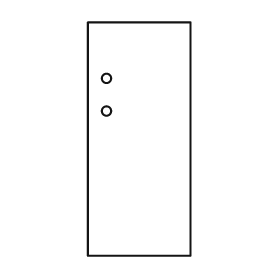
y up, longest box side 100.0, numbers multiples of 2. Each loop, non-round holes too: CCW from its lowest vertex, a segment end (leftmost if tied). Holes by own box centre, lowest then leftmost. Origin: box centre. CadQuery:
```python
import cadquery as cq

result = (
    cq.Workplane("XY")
    .moveTo(-22.0, -50.0)
    .lineTo(22.0, -50.0)
    .lineTo(22.0, 50.0)
    .lineTo(-22.0, 50.0)
    .close()
    .moveTo(-14.0, 12.0)
    .circle(2.0)
    .moveTo(-14.0, 26.0)
    .circle(2.0)
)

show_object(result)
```